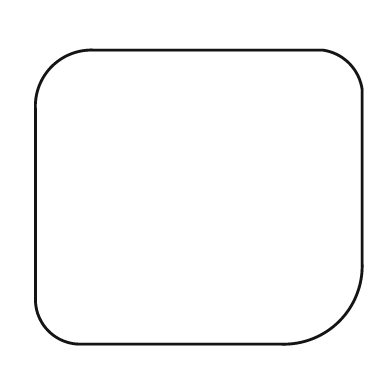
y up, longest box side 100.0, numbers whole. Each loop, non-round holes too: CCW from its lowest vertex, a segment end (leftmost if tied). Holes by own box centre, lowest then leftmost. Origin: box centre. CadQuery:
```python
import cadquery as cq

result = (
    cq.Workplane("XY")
    .moveTo(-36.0, -45.0)
    .lineTo(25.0, -45.0)
    .threePointArc((43.0, -38.0), (50.0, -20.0))
    .lineTo(50.0, 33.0)
    .threePointArc((46.0, 41.0), (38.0, 45.0))
    .lineTo(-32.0, 45.0)
    .threePointArc((-45.0, 40.0), (-50.0, 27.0))
    .lineTo(-50.0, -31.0)
    .threePointArc((-46.0, -41.0), (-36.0, -45.0))
    .close()
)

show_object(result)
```